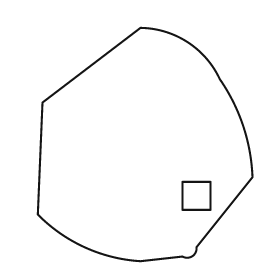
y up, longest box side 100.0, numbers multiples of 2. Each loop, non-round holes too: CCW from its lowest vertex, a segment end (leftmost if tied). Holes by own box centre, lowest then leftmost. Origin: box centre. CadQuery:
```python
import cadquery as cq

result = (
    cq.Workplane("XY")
    .moveTo(-2.0, -50.0)
    .lineTo(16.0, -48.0)
    .threePointArc((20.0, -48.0), (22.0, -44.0))
    .lineTo(46.0, -14.0)
    .threePointArc((42.0, 8.0), (32.0, 28.0))
    .threePointArc((18.0, 44.0), (-2.0, 50.0))
    .lineTo(-44.0, 18.0)
    .lineTo(-46.0, -30.0)
    .threePointArc((-26.0, -44.0), (-2.0, -50.0))
    .close()
    .moveTo(16.0, -28.0)
    .lineTo(28.0, -28.0)
    .lineTo(28.0, -16.0)
    .lineTo(16.0, -16.0)
    .close()
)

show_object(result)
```